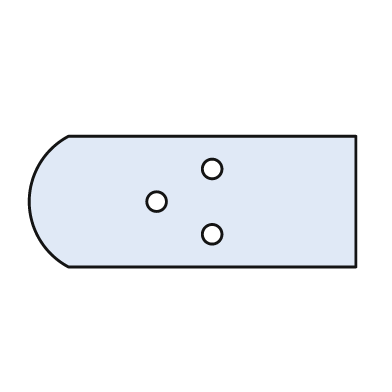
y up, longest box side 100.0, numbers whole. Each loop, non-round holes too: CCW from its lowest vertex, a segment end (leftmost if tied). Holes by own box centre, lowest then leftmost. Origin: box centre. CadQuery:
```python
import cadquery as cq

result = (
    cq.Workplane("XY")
    .moveTo(-38.0, -20.0)
    .lineTo(50.0, -20.0)
    .lineTo(50.0, 20.0)
    .lineTo(-38.0, 20.0)
    .threePointArc((-50.0, 0.0), (-38.0, -20.0))
    .close()
    .moveTo(6.0, -10.0)
    .circle(3.0)
    .moveTo(-11.0, 0.0)
    .circle(3.0)
    .moveTo(6.0, 10.0)
    .circle(3.0)
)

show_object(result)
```